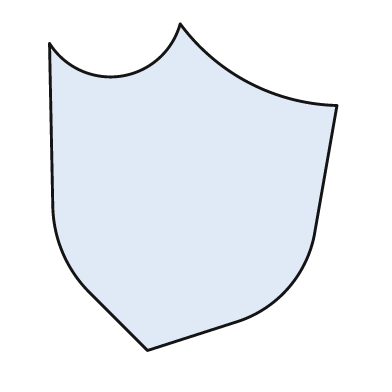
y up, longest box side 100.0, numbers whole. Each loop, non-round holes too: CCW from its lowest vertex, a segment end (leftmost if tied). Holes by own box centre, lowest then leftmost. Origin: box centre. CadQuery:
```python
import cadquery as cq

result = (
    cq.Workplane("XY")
    .moveTo(-14.0, -50.0)
    .lineTo(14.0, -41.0)
    .threePointArc((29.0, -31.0), (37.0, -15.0))
    .lineTo(44.0, 25.0)
    .threePointArc((17.0, 32.0), (-4.0, 50.0))
    .threePointArc((-22.0, 34.0), (-44.0, 44.0))
    .lineTo(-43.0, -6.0)
    .threePointArc((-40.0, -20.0), (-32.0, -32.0))
    .close()
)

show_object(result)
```